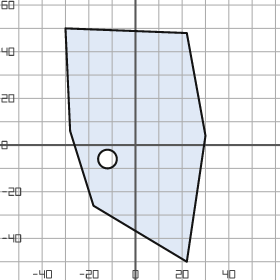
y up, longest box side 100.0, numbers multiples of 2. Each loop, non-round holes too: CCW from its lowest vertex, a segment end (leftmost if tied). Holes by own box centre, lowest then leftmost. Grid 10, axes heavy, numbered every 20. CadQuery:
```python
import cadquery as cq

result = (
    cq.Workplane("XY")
    .moveTo(22.0, -50.0)
    .lineTo(30.0, 4.0)
    .lineTo(22.0, 48.0)
    .lineTo(-30.0, 50.0)
    .lineTo(-28.0, 6.0)
    .lineTo(-18.0, -26.0)
    .close()
    .moveTo(-12.0, -6.0)
    .circle(4.0)
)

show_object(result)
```